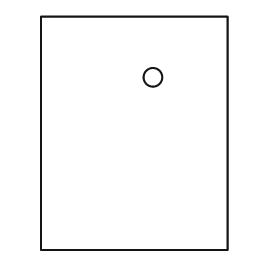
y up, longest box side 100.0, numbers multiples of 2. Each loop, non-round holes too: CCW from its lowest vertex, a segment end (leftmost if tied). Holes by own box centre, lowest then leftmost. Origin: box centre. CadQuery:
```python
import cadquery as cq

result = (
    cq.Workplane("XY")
    .moveTo(-40.0, -50.0)
    .lineTo(40.0, -50.0)
    .lineTo(40.0, 50.0)
    .lineTo(-40.0, 50.0)
    .close()
    .moveTo(8.0, 24.0)
    .circle(4.0)
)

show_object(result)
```